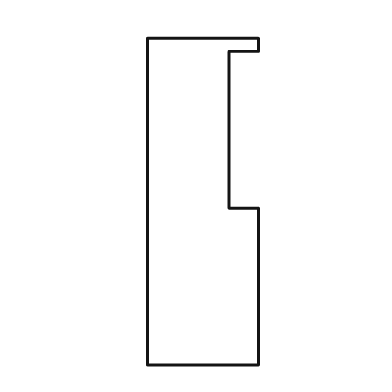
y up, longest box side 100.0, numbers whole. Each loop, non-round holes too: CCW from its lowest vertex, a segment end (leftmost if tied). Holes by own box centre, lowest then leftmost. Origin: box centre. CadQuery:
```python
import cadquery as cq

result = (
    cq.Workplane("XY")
    .moveTo(-17.0, -50.0)
    .lineTo(17.0, -50.0)
    .lineTo(17.0, -2.0)
    .lineTo(8.0, -2.0)
    .lineTo(8.0, 46.0)
    .lineTo(17.0, 46.0)
    .lineTo(17.0, 50.0)
    .lineTo(-17.0, 50.0)
    .close()
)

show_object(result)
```